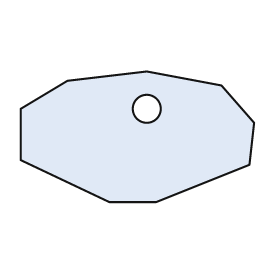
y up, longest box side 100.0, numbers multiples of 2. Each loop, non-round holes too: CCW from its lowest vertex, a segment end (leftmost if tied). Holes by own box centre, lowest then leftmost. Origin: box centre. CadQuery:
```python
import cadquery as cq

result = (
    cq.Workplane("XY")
    .moveTo(-12.0, -28.0)
    .lineTo(8.0, -28.0)
    .lineTo(48.0, -12.0)
    .lineTo(50.0, 6.0)
    .lineTo(36.0, 22.0)
    .lineTo(4.0, 28.0)
    .lineTo(-30.0, 24.0)
    .lineTo(-50.0, 12.0)
    .lineTo(-50.0, -10.0)
    .close()
    .moveTo(4.0, 12.0)
    .circle(6.0)
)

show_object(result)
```